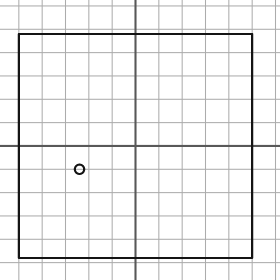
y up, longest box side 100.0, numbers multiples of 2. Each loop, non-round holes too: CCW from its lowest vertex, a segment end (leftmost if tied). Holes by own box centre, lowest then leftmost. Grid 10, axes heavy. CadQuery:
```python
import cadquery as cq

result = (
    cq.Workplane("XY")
    .moveTo(-50.0, -48.0)
    .lineTo(50.0, -48.0)
    .lineTo(50.0, 48.0)
    .lineTo(-50.0, 48.0)
    .close()
    .moveTo(-24.0, -10.0)
    .circle(2.0)
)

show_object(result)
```